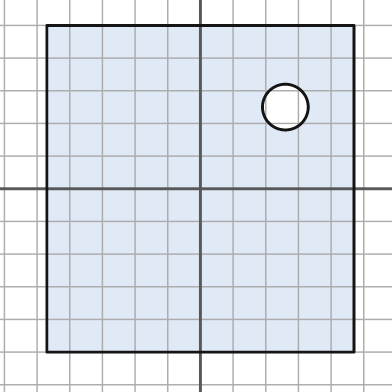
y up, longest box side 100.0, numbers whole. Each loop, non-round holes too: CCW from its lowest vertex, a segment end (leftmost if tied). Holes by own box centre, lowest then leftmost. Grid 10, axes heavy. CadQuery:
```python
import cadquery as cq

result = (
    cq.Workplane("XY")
    .moveTo(-47.0, -50.0)
    .lineTo(47.0, -50.0)
    .lineTo(47.0, 50.0)
    .lineTo(-47.0, 50.0)
    .close()
    .moveTo(26.0, 25.0)
    .circle(7.0)
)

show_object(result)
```